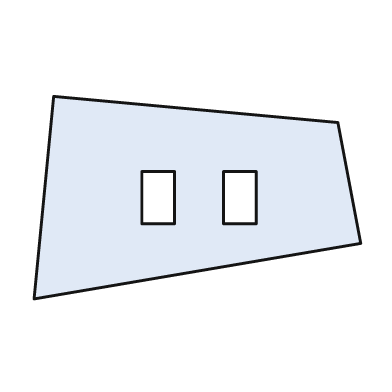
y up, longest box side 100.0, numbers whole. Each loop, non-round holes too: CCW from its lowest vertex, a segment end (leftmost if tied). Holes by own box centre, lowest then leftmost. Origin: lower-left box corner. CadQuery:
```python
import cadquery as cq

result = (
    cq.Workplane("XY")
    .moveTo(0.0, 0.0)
    .lineTo(100.0, 17.0)
    .lineTo(93.0, 54.0)
    .lineTo(6.0, 62.0)
    .close()
    .moveTo(33.0, 23.0)
    .lineTo(43.0, 23.0)
    .lineTo(43.0, 39.0)
    .lineTo(33.0, 39.0)
    .close()
    .moveTo(58.0, 23.0)
    .lineTo(68.0, 23.0)
    .lineTo(68.0, 39.0)
    .lineTo(58.0, 39.0)
    .close()
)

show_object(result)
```